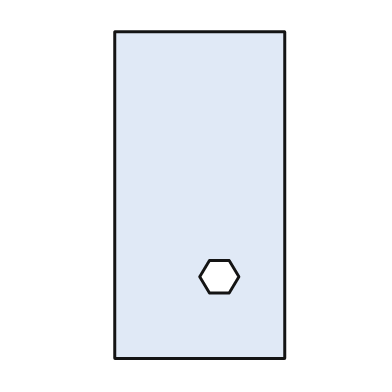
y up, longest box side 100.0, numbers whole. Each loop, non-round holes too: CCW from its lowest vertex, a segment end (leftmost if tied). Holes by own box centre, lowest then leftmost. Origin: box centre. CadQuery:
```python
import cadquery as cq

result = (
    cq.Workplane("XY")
    .moveTo(-26.0, -50.0)
    .lineTo(26.0, -50.0)
    .lineTo(26.0, 50.0)
    .lineTo(-26.0, 50.0)
    .close()
    .moveTo(3.0, -30.0)
    .lineTo(9.0, -30.0)
    .lineTo(12.0, -25.0)
    .lineTo(9.0, -20.0)
    .lineTo(3.0, -20.0)
    .lineTo(0.0, -25.0)
    .close()
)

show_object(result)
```